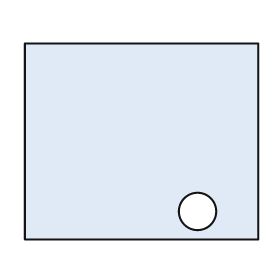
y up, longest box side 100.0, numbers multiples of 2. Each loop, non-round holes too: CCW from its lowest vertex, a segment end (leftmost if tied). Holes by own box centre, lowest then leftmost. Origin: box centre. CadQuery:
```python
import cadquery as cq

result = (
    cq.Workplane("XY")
    .moveTo(-50.0, -42.0)
    .lineTo(50.0, -42.0)
    .lineTo(50.0, 42.0)
    .lineTo(-50.0, 42.0)
    .close()
    .moveTo(24.0, -30.0)
    .circle(8.0)
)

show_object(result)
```